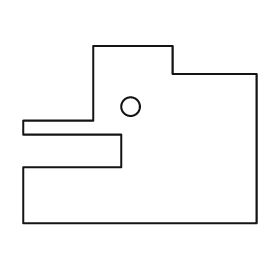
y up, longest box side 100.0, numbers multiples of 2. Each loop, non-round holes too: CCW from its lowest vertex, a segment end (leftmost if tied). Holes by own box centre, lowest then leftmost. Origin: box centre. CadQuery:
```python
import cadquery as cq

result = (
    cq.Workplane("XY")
    .moveTo(-50.0, -38.0)
    .lineTo(50.0, -38.0)
    .lineTo(50.0, 26.0)
    .lineTo(14.0, 26.0)
    .lineTo(14.0, 38.0)
    .lineTo(-20.0, 38.0)
    .lineTo(-20.0, 6.0)
    .lineTo(-50.0, 6.0)
    .lineTo(-50.0, 0.0)
    .lineTo(-8.0, 0.0)
    .lineTo(-8.0, -14.0)
    .lineTo(-50.0, -14.0)
    .close()
    .moveTo(-4.0, 12.0)
    .circle(4.0)
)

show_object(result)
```